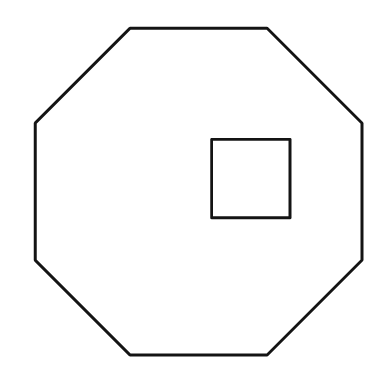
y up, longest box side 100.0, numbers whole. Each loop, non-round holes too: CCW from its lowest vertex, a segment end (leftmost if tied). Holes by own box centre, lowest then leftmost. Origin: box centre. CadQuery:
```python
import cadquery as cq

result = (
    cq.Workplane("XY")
    .moveTo(-21.0, -50.0)
    .lineTo(21.0, -50.0)
    .lineTo(50.0, -21.0)
    .lineTo(50.0, 21.0)
    .lineTo(21.0, 50.0)
    .lineTo(-21.0, 50.0)
    .lineTo(-50.0, 21.0)
    .lineTo(-50.0, -21.0)
    .close()
    .moveTo(4.0, -8.0)
    .lineTo(28.0, -8.0)
    .lineTo(28.0, 16.0)
    .lineTo(4.0, 16.0)
    .close()
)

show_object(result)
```